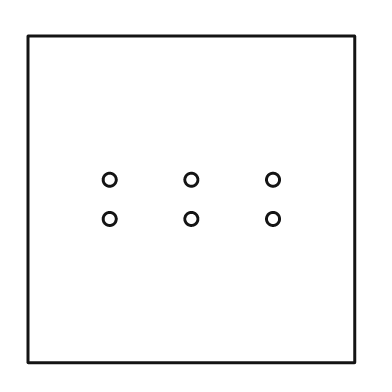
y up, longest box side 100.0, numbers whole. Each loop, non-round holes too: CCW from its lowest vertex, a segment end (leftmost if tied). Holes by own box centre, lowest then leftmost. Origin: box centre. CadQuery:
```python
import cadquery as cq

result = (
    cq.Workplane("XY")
    .moveTo(-50.0, -50.0)
    .lineTo(50.0, -50.0)
    .lineTo(50.0, 50.0)
    .lineTo(-50.0, 50.0)
    .close()
    .moveTo(-25.0, -6.0)
    .circle(2.0)
    .moveTo(0.0, -6.0)
    .circle(2.0)
    .moveTo(25.0, -6.0)
    .circle(2.0)
    .moveTo(-25.0, 6.0)
    .circle(2.0)
    .moveTo(0.0, 6.0)
    .circle(2.0)
    .moveTo(25.0, 6.0)
    .circle(2.0)
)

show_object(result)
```